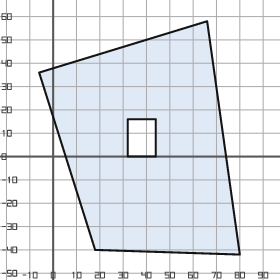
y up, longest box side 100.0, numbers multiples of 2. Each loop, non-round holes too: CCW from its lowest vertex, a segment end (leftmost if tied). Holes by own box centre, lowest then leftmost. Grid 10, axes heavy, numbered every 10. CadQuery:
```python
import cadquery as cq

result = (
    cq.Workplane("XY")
    .moveTo(80.0, -42.0)
    .lineTo(66.0, 58.0)
    .lineTo(-6.0, 36.0)
    .lineTo(18.0, -40.0)
    .close()
    .moveTo(32.0, 0.0)
    .lineTo(44.0, 0.0)
    .lineTo(44.0, 16.0)
    .lineTo(32.0, 16.0)
    .close()
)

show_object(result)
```